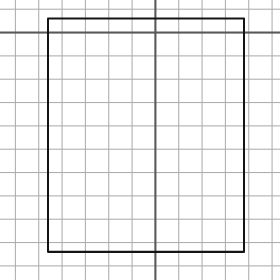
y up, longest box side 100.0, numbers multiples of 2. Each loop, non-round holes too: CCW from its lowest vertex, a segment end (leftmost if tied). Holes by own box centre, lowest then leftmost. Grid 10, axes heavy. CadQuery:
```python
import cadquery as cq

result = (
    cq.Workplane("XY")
    .moveTo(-46.0, -94.0)
    .lineTo(38.0, -94.0)
    .lineTo(38.0, 6.0)
    .lineTo(-46.0, 6.0)
    .close()
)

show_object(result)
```